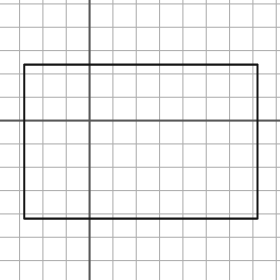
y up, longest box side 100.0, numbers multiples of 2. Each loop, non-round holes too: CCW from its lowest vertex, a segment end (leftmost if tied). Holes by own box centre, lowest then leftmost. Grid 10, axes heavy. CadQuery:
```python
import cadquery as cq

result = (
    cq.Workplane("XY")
    .moveTo(-28.0, -42.0)
    .lineTo(72.0, -42.0)
    .lineTo(72.0, 24.0)
    .lineTo(-28.0, 24.0)
    .close()
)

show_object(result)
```